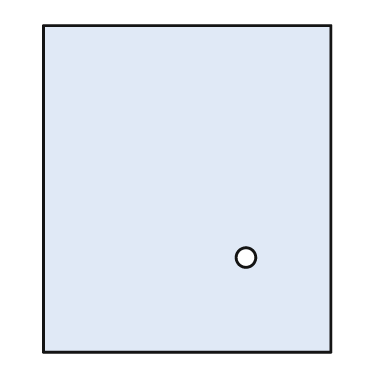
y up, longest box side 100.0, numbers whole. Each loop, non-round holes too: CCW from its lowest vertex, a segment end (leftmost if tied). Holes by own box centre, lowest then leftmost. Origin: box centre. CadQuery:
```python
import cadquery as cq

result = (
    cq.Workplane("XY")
    .moveTo(-44.0, -50.0)
    .lineTo(44.0, -50.0)
    .lineTo(44.0, 50.0)
    .lineTo(-44.0, 50.0)
    .close()
    .moveTo(18.0, -21.0)
    .circle(3.0)
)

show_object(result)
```